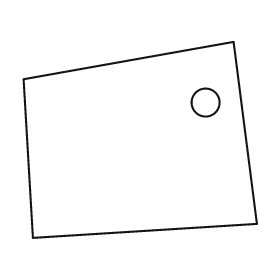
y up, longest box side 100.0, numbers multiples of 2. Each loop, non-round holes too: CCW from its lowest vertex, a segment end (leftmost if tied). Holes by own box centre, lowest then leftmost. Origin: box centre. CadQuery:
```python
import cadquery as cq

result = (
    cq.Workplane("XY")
    .moveTo(-46.0, -42.0)
    .lineTo(50.0, -36.0)
    .lineTo(40.0, 42.0)
    .lineTo(-50.0, 26.0)
    .close()
    .moveTo(28.0, 16.0)
    .circle(6.0)
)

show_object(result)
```